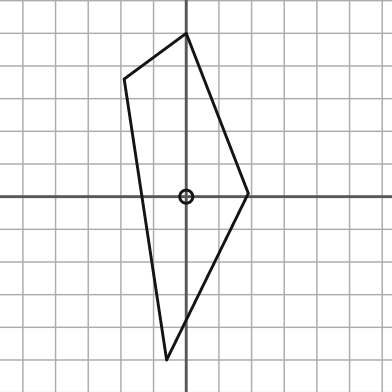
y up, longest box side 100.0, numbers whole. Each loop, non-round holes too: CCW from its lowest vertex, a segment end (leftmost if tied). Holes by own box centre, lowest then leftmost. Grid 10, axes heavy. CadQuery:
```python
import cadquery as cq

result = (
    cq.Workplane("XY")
    .moveTo(-6.0, -50.0)
    .lineTo(19.0, 1.0)
    .lineTo(0.0, 50.0)
    .lineTo(-19.0, 36.0)
    .close()
    .moveTo(0.0, 0.0)
    .circle(2.0)
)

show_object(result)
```